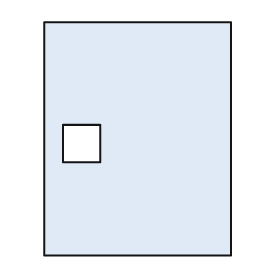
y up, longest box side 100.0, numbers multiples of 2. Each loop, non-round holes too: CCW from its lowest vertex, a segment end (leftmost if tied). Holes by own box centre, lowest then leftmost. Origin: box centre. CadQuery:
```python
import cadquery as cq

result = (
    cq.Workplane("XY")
    .moveTo(-40.0, -50.0)
    .lineTo(40.0, -50.0)
    .lineTo(40.0, 50.0)
    .lineTo(-40.0, 50.0)
    .close()
    .moveTo(-32.0, -10.0)
    .lineTo(-16.0, -10.0)
    .lineTo(-16.0, 6.0)
    .lineTo(-32.0, 6.0)
    .close()
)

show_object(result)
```